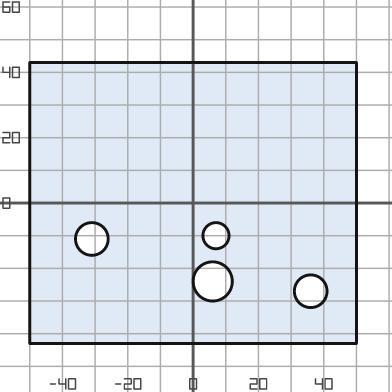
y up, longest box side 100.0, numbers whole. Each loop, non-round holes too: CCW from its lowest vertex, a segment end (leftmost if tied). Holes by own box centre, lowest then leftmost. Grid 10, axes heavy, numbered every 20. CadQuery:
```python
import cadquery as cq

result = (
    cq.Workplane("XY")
    .moveTo(-50.0, -43.0)
    .lineTo(50.0, -43.0)
    .lineTo(50.0, 43.0)
    .lineTo(-50.0, 43.0)
    .close()
    .moveTo(36.0, -27.0)
    .circle(5.0)
    .moveTo(6.0, -24.0)
    .circle(6.0)
    .moveTo(-31.0, -11.0)
    .circle(5.0)
    .moveTo(7.0, -10.0)
    .circle(4.0)
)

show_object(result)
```